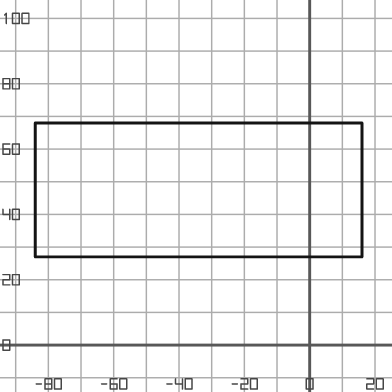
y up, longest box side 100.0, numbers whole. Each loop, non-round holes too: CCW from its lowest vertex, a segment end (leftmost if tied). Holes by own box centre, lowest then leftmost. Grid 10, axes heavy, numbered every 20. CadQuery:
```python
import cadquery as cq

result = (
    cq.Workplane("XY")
    .moveTo(-84.0, 27.0)
    .lineTo(16.0, 27.0)
    .lineTo(16.0, 68.0)
    .lineTo(-84.0, 68.0)
    .close()
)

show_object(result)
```